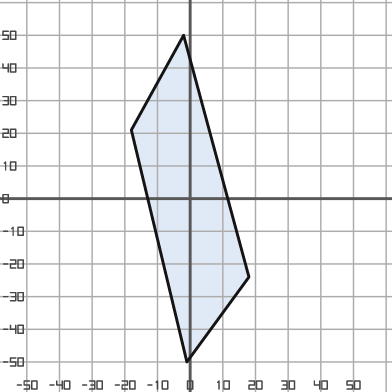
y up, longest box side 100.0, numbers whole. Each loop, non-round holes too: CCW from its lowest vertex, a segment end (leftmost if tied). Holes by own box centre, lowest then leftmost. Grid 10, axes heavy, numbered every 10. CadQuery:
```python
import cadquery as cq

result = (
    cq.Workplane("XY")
    .moveTo(-1.0, -50.0)
    .lineTo(18.0, -24.0)
    .lineTo(-2.0, 50.0)
    .lineTo(-18.0, 21.0)
    .close()
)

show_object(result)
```